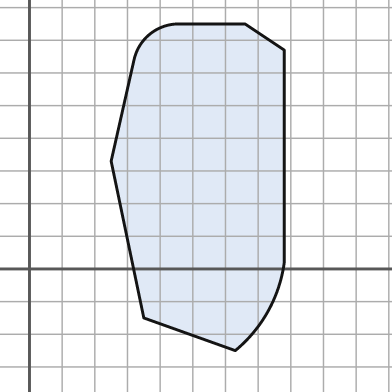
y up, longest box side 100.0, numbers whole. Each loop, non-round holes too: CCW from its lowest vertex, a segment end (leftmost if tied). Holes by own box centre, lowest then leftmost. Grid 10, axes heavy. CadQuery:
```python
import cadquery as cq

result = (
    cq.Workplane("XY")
    .moveTo(63.0, -25.0)
    .threePointArc((73.0, -13.0), (78.0, 2.0))
    .lineTo(78.0, 67.0)
    .lineTo(66.0, 75.0)
    .lineTo(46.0, 75.0)
    .threePointArc((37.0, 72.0), (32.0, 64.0))
    .lineTo(25.0, 33.0)
    .lineTo(35.0, -15.0)
    .close()
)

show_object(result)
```